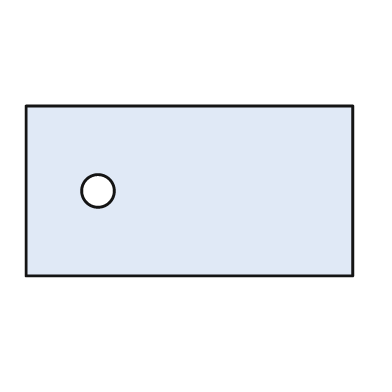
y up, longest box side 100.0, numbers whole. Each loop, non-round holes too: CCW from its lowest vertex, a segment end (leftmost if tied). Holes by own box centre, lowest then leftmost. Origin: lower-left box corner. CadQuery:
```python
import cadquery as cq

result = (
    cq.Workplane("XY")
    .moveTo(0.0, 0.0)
    .lineTo(100.0, 0.0)
    .lineTo(100.0, 52.0)
    .lineTo(0.0, 52.0)
    .close()
    .moveTo(22.0, 26.0)
    .circle(5.0)
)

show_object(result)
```